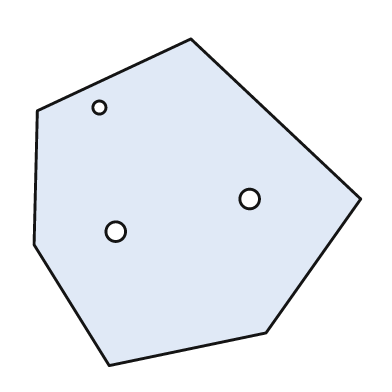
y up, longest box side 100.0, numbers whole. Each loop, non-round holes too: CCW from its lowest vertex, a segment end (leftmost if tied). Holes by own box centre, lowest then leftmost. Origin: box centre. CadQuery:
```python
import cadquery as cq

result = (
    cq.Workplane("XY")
    .moveTo(-27.0, -50.0)
    .lineTo(21.0, -40.0)
    .lineTo(50.0, 1.0)
    .lineTo(-2.0, 50.0)
    .lineTo(-49.0, 28.0)
    .lineTo(-50.0, -13.0)
    .close()
    .moveTo(-25.0, -9.0)
    .circle(3.0)
    .moveTo(16.0, 1.0)
    .circle(3.0)
    .moveTo(-30.0, 29.0)
    .circle(2.0)
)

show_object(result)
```